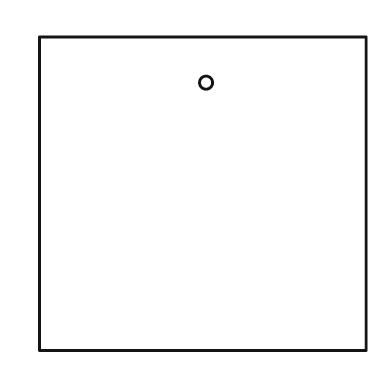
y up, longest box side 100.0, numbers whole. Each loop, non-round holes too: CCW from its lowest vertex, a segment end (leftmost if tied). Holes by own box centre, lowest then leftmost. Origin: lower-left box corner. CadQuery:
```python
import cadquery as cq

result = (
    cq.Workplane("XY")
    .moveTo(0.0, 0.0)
    .lineTo(100.0, 0.0)
    .lineTo(100.0, 96.0)
    .lineTo(0.0, 96.0)
    .close()
    .moveTo(51.0, 82.0)
    .circle(2.0)
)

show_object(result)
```